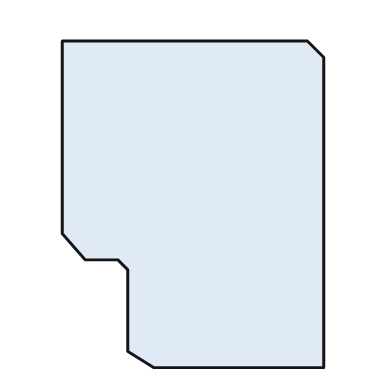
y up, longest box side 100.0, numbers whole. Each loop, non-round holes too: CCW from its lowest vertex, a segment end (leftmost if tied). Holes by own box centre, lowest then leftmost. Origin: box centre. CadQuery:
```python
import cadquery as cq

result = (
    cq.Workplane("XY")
    .moveTo(-12.0, -50.0)
    .lineTo(40.0, -50.0)
    .lineTo(40.0, 45.0)
    .lineTo(35.0, 50.0)
    .lineTo(-40.0, 50.0)
    .lineTo(-40.0, -9.0)
    .lineTo(-33.0, -17.0)
    .lineTo(-23.0, -17.0)
    .lineTo(-20.0, -20.0)
    .lineTo(-20.0, -45.0)
    .close()
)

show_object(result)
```